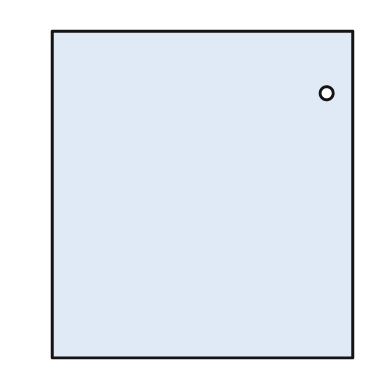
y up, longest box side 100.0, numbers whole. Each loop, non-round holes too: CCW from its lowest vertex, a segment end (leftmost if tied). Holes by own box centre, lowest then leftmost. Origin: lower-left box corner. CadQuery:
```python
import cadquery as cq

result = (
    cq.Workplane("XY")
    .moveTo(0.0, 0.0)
    .lineTo(92.0, 0.0)
    .lineTo(92.0, 100.0)
    .lineTo(0.0, 100.0)
    .close()
    .moveTo(84.0, 81.0)
    .circle(2.0)
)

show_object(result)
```